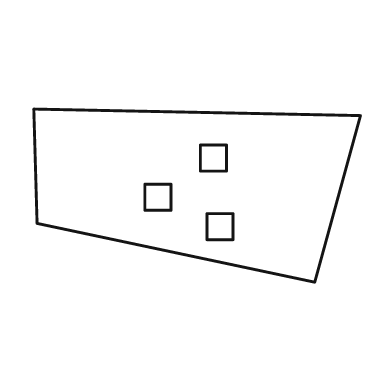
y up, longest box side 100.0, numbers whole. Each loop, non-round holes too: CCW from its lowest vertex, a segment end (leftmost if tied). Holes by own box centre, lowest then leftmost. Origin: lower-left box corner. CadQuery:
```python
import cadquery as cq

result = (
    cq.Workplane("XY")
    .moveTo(86.0, 0.0)
    .lineTo(100.0, 51.0)
    .lineTo(0.0, 53.0)
    .lineTo(1.0, 18.0)
    .close()
    .moveTo(53.0, 13.0)
    .lineTo(61.0, 13.0)
    .lineTo(61.0, 21.0)
    .lineTo(53.0, 21.0)
    .close()
    .moveTo(34.0, 22.0)
    .lineTo(42.0, 22.0)
    .lineTo(42.0, 30.0)
    .lineTo(34.0, 30.0)
    .close()
    .moveTo(51.0, 34.0)
    .lineTo(59.0, 34.0)
    .lineTo(59.0, 42.0)
    .lineTo(51.0, 42.0)
    .close()
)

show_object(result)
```